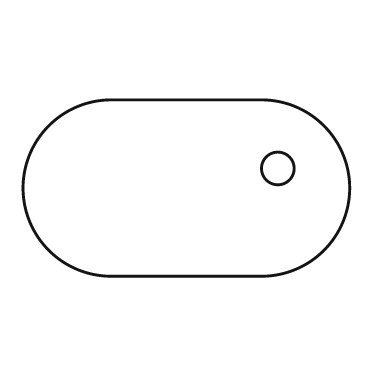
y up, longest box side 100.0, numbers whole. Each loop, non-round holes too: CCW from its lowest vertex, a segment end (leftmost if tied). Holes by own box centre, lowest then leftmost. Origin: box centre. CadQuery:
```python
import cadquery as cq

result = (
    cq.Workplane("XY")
    .moveTo(-23.0, -27.0)
    .lineTo(23.0, -27.0)
    .threePointArc((50.0, 0.0), (23.0, 27.0))
    .lineTo(-23.0, 27.0)
    .threePointArc((-50.0, 0.0), (-23.0, -27.0))
    .close()
    .moveTo(28.0, 6.0)
    .circle(5.0)
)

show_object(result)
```